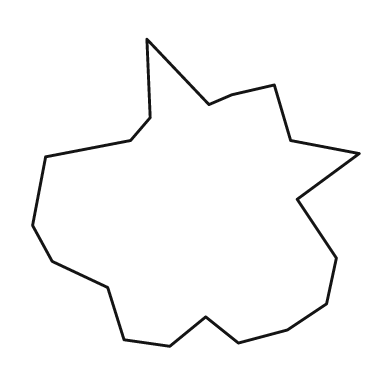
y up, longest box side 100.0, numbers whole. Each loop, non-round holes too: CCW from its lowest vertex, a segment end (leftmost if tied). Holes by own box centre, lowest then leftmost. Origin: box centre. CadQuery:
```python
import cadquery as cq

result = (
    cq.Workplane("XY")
    .moveTo(-8.0, -47.0)
    .lineTo(3.0, -38.0)
    .lineTo(13.0, -46.0)
    .lineTo(28.0, -42.0)
    .lineTo(40.0, -34.0)
    .lineTo(43.0, -20.0)
    .lineTo(31.0, -2.0)
    .lineTo(50.0, 12.0)
    .lineTo(29.0, 16.0)
    .lineTo(24.0, 33.0)
    .lineTo(11.0, 30.0)
    .lineTo(4.0, 27.0)
    .lineTo(-15.0, 47.0)
    .lineTo(-14.0, 23.0)
    .lineTo(-20.0, 16.0)
    .lineTo(-46.0, 11.0)
    .lineTo(-50.0, -10.0)
    .lineTo(-44.0, -21.0)
    .lineTo(-27.0, -29.0)
    .lineTo(-22.0, -45.0)
    .close()
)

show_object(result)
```